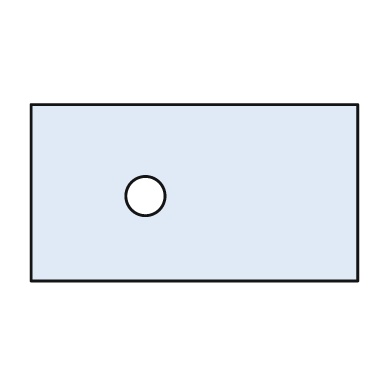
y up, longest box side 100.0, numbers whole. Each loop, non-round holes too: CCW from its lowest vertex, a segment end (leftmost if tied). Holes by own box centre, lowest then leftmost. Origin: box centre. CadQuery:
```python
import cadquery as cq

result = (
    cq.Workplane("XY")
    .moveTo(-50.0, -27.0)
    .lineTo(50.0, -27.0)
    .lineTo(50.0, 27.0)
    .lineTo(-50.0, 27.0)
    .close()
    .moveTo(-15.0, -1.0)
    .circle(6.0)
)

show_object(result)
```